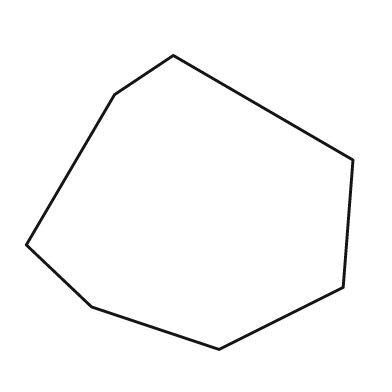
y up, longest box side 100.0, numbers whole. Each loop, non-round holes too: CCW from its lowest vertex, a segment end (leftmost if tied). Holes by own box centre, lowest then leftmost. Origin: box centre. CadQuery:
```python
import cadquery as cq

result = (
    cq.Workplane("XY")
    .moveTo(9.0, -45.0)
    .lineTo(47.0, -26.0)
    .lineTo(50.0, 13.0)
    .lineTo(-5.0, 45.0)
    .lineTo(-23.0, 33.0)
    .lineTo(-50.0, -13.0)
    .lineTo(-30.0, -32.0)
    .close()
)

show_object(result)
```